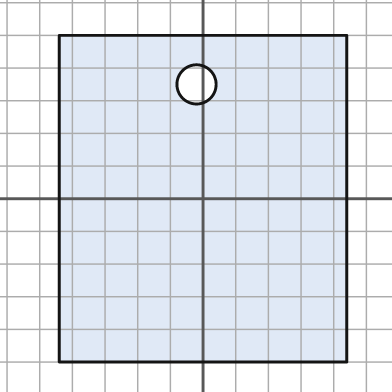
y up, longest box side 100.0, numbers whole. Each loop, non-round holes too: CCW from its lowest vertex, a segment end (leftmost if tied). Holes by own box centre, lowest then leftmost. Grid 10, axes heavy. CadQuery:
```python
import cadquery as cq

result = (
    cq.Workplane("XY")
    .moveTo(-44.0, -50.0)
    .lineTo(44.0, -50.0)
    .lineTo(44.0, 50.0)
    .lineTo(-44.0, 50.0)
    .close()
    .moveTo(-2.0, 35.0)
    .circle(6.0)
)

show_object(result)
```